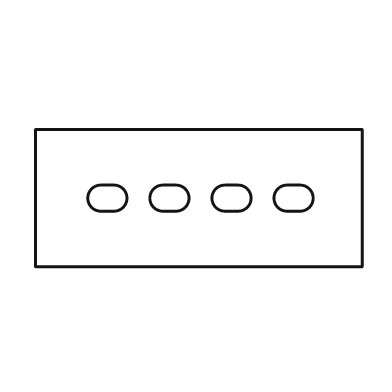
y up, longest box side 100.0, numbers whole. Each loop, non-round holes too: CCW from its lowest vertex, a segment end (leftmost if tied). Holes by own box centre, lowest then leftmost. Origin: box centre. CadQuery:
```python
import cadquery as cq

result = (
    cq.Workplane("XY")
    .moveTo(-50.0, -21.0)
    .lineTo(50.0, -21.0)
    .lineTo(50.0, 21.0)
    .lineTo(-50.0, 21.0)
    .close()
    .moveTo(-30.0, -4.0)
    .lineTo(-26.0, -4.0)
    .threePointArc((-22.0, 0.0), (-26.0, 4.0))
    .lineTo(-30.0, 4.0)
    .threePointArc((-34.0, 0.0), (-30.0, -4.0))
    .close()
    .moveTo(-11.0, -4.0)
    .lineTo(-7.0, -4.0)
    .threePointArc((-3.0, 0.0), (-7.0, 4.0))
    .lineTo(-11.0, 4.0)
    .threePointArc((-15.0, 0.0), (-11.0, -4.0))
    .close()
    .moveTo(8.0, -4.0)
    .lineTo(12.0, -4.0)
    .threePointArc((16.0, 0.0), (12.0, 4.0))
    .lineTo(8.0, 4.0)
    .threePointArc((4.0, 0.0), (8.0, -4.0))
    .close()
    .moveTo(27.0, -4.0)
    .lineTo(31.0, -4.0)
    .threePointArc((35.0, 0.0), (31.0, 4.0))
    .lineTo(27.0, 4.0)
    .threePointArc((23.0, 0.0), (27.0, -4.0))
    .close()
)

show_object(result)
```